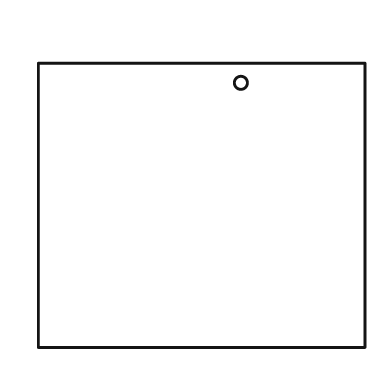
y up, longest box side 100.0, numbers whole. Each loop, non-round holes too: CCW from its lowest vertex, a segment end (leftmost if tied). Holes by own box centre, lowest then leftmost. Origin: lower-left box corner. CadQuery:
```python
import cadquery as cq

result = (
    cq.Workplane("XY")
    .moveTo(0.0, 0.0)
    .lineTo(100.0, 0.0)
    .lineTo(100.0, 87.0)
    .lineTo(0.0, 87.0)
    .close()
    .moveTo(62.0, 81.0)
    .circle(2.0)
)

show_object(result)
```